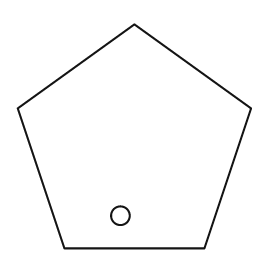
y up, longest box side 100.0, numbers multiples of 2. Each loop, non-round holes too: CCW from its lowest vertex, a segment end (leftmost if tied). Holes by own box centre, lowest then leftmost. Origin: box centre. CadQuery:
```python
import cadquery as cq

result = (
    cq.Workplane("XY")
    .moveTo(-30.0, -48.0)
    .lineTo(30.0, -48.0)
    .lineTo(50.0, 12.0)
    .lineTo(0.0, 48.0)
    .lineTo(-50.0, 12.0)
    .close()
    .moveTo(-6.0, -34.0)
    .circle(4.0)
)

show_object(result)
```